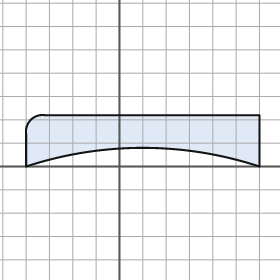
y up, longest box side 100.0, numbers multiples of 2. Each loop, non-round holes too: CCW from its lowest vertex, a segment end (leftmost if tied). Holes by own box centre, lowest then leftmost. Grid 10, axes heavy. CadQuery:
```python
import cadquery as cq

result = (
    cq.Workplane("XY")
    .moveTo(-40.0, 0.0)
    .threePointArc((10.0, 8.0), (60.0, 0.0))
    .lineTo(60.0, 22.0)
    .lineTo(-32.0, 22.0)
    .threePointArc((-38.0, 20.0), (-40.0, 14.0))
    .close()
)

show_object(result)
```